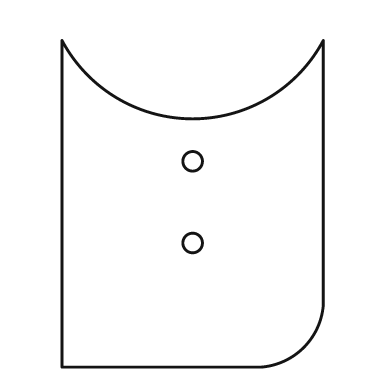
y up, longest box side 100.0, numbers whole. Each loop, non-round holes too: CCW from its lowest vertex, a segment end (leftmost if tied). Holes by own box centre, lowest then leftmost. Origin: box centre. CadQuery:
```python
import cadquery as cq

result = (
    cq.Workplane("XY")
    .moveTo(-40.0, -50.0)
    .lineTo(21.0, -50.0)
    .threePointArc((34.0, -44.0), (40.0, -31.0))
    .lineTo(40.0, 50.0)
    .threePointArc((0.0, 26.0), (-40.0, 50.0))
    .close()
    .moveTo(0.0, -12.0)
    .circle(3.0)
    .moveTo(0.0, 13.0)
    .circle(3.0)
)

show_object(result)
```